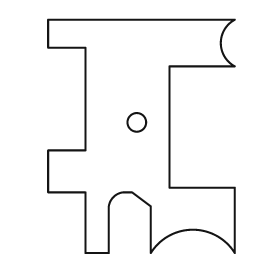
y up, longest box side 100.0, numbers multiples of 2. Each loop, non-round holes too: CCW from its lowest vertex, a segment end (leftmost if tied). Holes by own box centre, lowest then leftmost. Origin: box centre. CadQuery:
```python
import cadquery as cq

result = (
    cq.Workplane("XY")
    .moveTo(-24.0, -50.0)
    .lineTo(-14.0, -50.0)
    .lineTo(-14.0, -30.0)
    .threePointArc((-12.0, -26.0), (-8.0, -24.0))
    .lineTo(-4.0, -24.0)
    .lineTo(4.0, -30.0)
    .lineTo(4.0, -50.0)
    .threePointArc((22.0, -40.0), (40.0, -50.0))
    .lineTo(40.0, -22.0)
    .lineTo(12.0, -22.0)
    .lineTo(12.0, 30.0)
    .lineTo(40.0, 30.0)
    .threePointArc((34.0, 40.0), (40.0, 50.0))
    .lineTo(-40.0, 50.0)
    .lineTo(-40.0, 38.0)
    .lineTo(-24.0, 38.0)
    .lineTo(-24.0, -6.0)
    .lineTo(-40.0, -6.0)
    .lineTo(-40.0, -24.0)
    .lineTo(-24.0, -24.0)
    .close()
    .moveTo(-2.0, 6.0)
    .circle(4.0)
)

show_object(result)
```